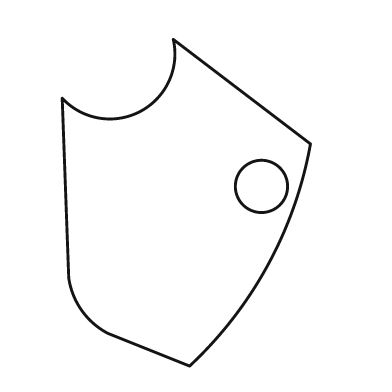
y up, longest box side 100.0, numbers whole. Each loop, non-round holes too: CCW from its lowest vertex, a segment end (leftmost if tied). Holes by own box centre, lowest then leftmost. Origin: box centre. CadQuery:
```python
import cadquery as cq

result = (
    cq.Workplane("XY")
    .moveTo(1.0, -50.0)
    .threePointArc((25.0, -19.0), (38.0, 18.0))
    .lineTo(-4.0, 50.0)
    .threePointArc((-14.0, 28.0), (-38.0, 32.0))
    .lineTo(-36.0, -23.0)
    .threePointArc((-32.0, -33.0), (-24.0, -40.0))
    .close()
    .moveTo(23.0, 5.0)
    .circle(8.0)
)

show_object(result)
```